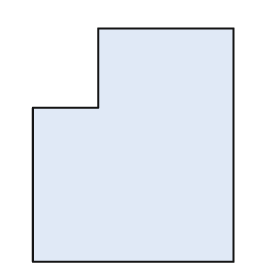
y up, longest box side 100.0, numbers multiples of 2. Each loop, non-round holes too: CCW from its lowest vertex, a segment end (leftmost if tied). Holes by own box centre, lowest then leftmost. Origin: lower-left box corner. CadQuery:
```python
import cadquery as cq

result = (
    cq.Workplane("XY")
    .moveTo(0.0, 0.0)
    .lineTo(86.0, 0.0)
    .lineTo(86.0, 100.0)
    .lineTo(28.0, 100.0)
    .lineTo(28.0, 66.0)
    .lineTo(0.0, 66.0)
    .close()
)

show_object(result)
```